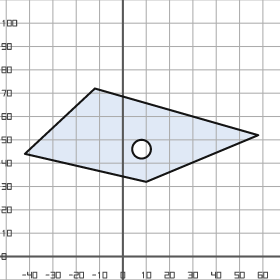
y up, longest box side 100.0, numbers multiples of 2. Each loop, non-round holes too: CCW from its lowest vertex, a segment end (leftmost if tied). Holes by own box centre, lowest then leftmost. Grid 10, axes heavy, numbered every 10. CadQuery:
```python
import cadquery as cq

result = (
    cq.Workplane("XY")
    .moveTo(10.0, 32.0)
    .lineTo(58.0, 52.0)
    .lineTo(-12.0, 72.0)
    .lineTo(-42.0, 44.0)
    .close()
    .moveTo(8.0, 46.0)
    .circle(4.0)
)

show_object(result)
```